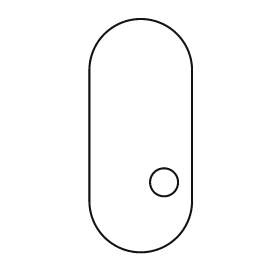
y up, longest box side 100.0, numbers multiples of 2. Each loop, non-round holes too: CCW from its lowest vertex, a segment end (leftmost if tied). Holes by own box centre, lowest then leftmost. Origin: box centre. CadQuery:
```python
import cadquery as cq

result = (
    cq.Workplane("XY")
    .moveTo(-22.0, -28.0)
    .threePointArc((0.0, -50.0), (22.0, -28.0))
    .lineTo(22.0, 28.0)
    .threePointArc((0.0, 50.0), (-22.0, 28.0))
    .close()
    .moveTo(10.0, -20.0)
    .circle(6.0)
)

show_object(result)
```